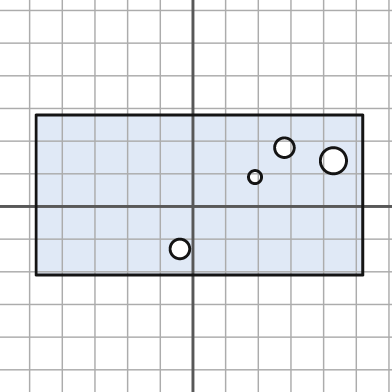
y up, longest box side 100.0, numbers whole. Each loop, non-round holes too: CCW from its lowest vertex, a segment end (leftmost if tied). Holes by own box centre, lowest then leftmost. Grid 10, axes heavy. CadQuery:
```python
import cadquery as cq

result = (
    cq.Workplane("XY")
    .moveTo(-48.0, -21.0)
    .lineTo(52.0, -21.0)
    .lineTo(52.0, 28.0)
    .lineTo(-48.0, 28.0)
    .close()
    .moveTo(-4.0, -13.0)
    .circle(3.0)
    .moveTo(19.0, 9.0)
    .circle(2.0)
    .moveTo(43.0, 14.0)
    .circle(4.0)
    .moveTo(28.0, 18.0)
    .circle(3.0)
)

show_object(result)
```